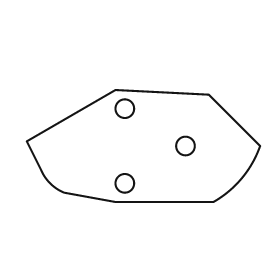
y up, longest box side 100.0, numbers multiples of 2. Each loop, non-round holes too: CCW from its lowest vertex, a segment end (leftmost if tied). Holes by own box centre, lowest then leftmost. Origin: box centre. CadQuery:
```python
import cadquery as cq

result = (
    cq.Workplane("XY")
    .moveTo(-12.0, -24.0)
    .lineTo(30.0, -24.0)
    .threePointArc((42.0, -14.0), (50.0, 0.0))
    .lineTo(28.0, 22.0)
    .lineTo(-12.0, 24.0)
    .lineTo(-50.0, 2.0)
    .lineTo(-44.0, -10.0)
    .threePointArc((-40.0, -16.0), (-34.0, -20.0))
    .close()
    .moveTo(-8.0, -16.0)
    .circle(4.0)
    .moveTo(18.0, 0.0)
    .circle(4.0)
    .moveTo(-8.0, 16.0)
    .circle(4.0)
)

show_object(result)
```